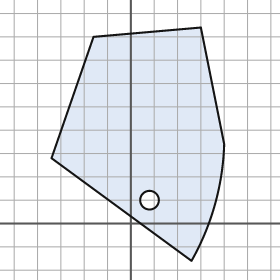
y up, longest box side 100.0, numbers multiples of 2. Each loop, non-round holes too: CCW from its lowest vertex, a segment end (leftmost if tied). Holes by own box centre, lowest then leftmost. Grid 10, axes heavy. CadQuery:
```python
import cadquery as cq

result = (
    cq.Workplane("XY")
    .moveTo(26.0, -16.0)
    .threePointArc((36.0, 8.0), (40.0, 34.0))
    .lineTo(30.0, 84.0)
    .lineTo(-16.0, 80.0)
    .lineTo(-34.0, 28.0)
    .close()
    .moveTo(8.0, 10.0)
    .circle(4.0)
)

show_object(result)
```